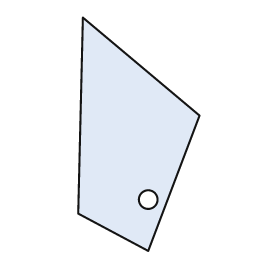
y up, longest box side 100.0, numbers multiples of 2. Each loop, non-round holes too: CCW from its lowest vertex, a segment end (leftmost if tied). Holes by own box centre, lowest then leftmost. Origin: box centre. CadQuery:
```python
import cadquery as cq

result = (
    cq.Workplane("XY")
    .moveTo(4.0, -50.0)
    .lineTo(26.0, 8.0)
    .lineTo(-24.0, 50.0)
    .lineTo(-26.0, -34.0)
    .close()
    .moveTo(4.0, -28.0)
    .circle(4.0)
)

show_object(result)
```